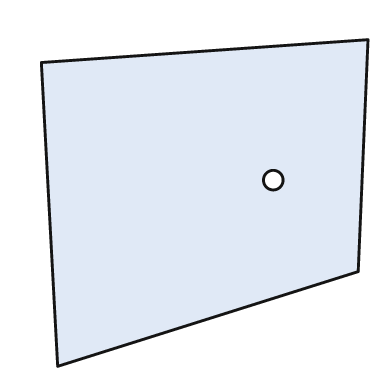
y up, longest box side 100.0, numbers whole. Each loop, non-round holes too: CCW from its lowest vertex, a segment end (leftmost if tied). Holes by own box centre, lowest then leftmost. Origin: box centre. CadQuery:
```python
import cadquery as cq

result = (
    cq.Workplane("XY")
    .moveTo(-45.0, -50.0)
    .lineTo(47.0, -21.0)
    .lineTo(50.0, 50.0)
    .lineTo(-50.0, 43.0)
    .close()
    .moveTo(21.0, 7.0)
    .circle(3.0)
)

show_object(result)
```